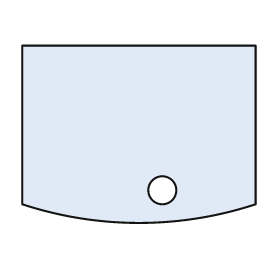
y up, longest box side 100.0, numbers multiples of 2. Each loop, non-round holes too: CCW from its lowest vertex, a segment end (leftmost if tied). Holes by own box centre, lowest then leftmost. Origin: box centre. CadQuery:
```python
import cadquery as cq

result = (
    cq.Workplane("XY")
    .moveTo(-50.0, -30.0)
    .threePointArc((0.0, -38.0), (50.0, -30.0))
    .lineTo(50.0, 38.0)
    .lineTo(-50.0, 38.0)
    .close()
    .moveTo(10.0, -24.0)
    .circle(6.0)
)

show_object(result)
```